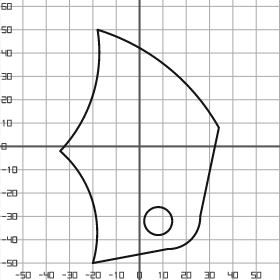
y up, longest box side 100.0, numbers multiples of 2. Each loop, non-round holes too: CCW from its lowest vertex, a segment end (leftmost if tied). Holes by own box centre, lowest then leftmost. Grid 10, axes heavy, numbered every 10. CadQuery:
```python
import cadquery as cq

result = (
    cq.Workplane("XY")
    .moveTo(-20.0, -50.0)
    .lineTo(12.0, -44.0)
    .threePointArc((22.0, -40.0), (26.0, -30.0))
    .lineTo(34.0, 8.0)
    .threePointArc((12.0, 34.0), (-18.0, 50.0))
    .threePointArc((-20.0, 22.0), (-34.0, -2.0))
    .threePointArc((-20.0, -24.0), (-20.0, -50.0))
    .close()
    .moveTo(8.0, -32.0)
    .circle(6.0)
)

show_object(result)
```